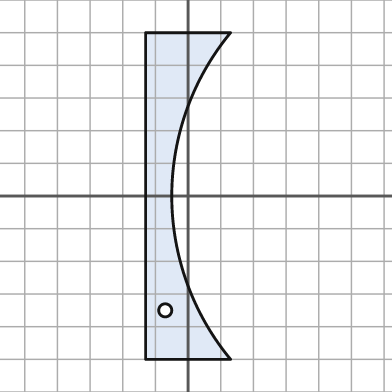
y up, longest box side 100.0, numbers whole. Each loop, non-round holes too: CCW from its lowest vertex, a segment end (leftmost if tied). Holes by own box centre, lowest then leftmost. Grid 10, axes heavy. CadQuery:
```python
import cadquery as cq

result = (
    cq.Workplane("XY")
    .moveTo(-13.0, -50.0)
    .lineTo(13.0, -50.0)
    .threePointArc((-5.0, 0.0), (13.0, 50.0))
    .lineTo(-13.0, 50.0)
    .close()
    .moveTo(-7.0, -35.0)
    .circle(2.0)
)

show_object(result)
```